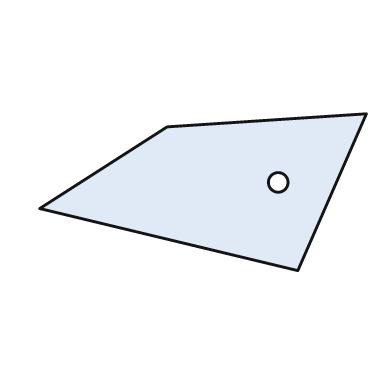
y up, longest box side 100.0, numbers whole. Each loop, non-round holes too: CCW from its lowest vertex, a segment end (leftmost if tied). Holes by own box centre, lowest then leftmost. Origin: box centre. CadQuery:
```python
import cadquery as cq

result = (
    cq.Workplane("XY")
    .moveTo(29.0, -24.0)
    .lineTo(50.0, 24.0)
    .lineTo(-11.0, 20.0)
    .lineTo(-50.0, -5.0)
    .close()
    .moveTo(23.0, 3.0)
    .circle(3.0)
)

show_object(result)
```